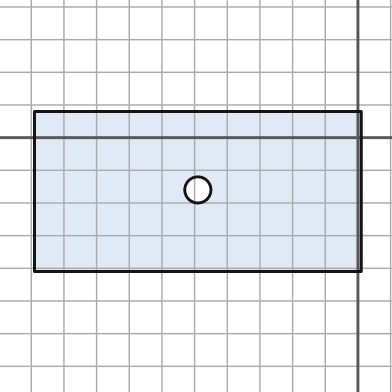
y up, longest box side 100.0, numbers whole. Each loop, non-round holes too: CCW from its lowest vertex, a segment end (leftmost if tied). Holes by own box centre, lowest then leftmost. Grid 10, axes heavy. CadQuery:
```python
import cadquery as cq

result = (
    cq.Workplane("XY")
    .moveTo(-99.0, -41.0)
    .lineTo(1.0, -41.0)
    .lineTo(1.0, 8.0)
    .lineTo(-99.0, 8.0)
    .close()
    .moveTo(-49.0, -16.0)
    .circle(4.0)
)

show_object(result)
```